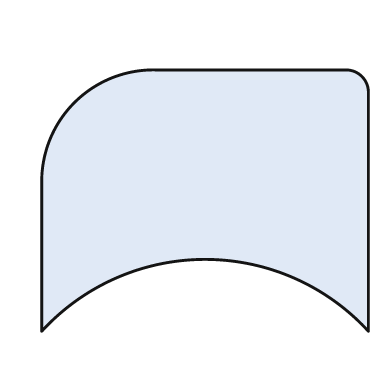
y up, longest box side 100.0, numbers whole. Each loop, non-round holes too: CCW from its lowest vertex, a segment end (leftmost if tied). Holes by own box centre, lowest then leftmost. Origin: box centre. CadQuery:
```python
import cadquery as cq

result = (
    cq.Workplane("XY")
    .moveTo(-50.0, -40.0)
    .threePointArc((0.0, -18.0), (50.0, -40.0))
    .lineTo(50.0, 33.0)
    .threePointArc((48.0, 38.0), (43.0, 40.0))
    .lineTo(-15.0, 40.0)
    .threePointArc((-40.0, 30.0), (-50.0, 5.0))
    .close()
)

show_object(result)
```